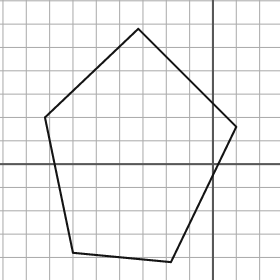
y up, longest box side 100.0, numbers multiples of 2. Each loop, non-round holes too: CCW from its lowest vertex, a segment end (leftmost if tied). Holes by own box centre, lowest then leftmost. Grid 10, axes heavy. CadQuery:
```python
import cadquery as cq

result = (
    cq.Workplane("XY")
    .moveTo(-18.0, -42.0)
    .lineTo(10.0, 16.0)
    .lineTo(-32.0, 58.0)
    .lineTo(-72.0, 20.0)
    .lineTo(-60.0, -38.0)
    .close()
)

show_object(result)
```